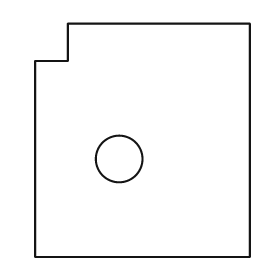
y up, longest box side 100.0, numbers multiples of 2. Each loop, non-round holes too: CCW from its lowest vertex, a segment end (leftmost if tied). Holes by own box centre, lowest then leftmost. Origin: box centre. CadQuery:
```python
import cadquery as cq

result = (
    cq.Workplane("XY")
    .moveTo(-46.0, -50.0)
    .lineTo(46.0, -50.0)
    .lineTo(46.0, 50.0)
    .lineTo(-32.0, 50.0)
    .lineTo(-32.0, 34.0)
    .lineTo(-46.0, 34.0)
    .close()
    .moveTo(-10.0, -8.0)
    .circle(10.0)
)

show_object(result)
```